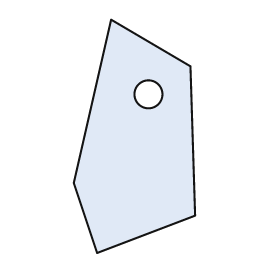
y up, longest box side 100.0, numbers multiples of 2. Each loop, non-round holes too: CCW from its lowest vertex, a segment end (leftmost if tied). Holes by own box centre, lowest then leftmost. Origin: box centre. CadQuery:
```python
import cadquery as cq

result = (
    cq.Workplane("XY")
    .moveTo(-16.0, -50.0)
    .lineTo(26.0, -34.0)
    .lineTo(24.0, 30.0)
    .lineTo(-10.0, 50.0)
    .lineTo(-26.0, -20.0)
    .close()
    .moveTo(6.0, 18.0)
    .circle(6.0)
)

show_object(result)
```